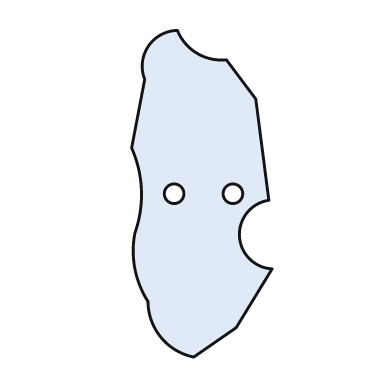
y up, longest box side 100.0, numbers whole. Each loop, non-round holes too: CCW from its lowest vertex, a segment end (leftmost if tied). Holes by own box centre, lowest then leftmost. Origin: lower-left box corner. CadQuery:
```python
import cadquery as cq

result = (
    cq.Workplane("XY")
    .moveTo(19.0, 0.0)
    .lineTo(32.0, 9.0)
    .lineTo(43.0, 27.0)
    .threePointArc((33.0, 37.0), (42.0, 48.0))
    .lineTo(38.0, 79.0)
    .lineTo(29.0, 91.0)
    .threePointArc((20.0, 93.0), (14.0, 100.0))
    .threePointArc((5.0, 95.0), (4.0, 85.0))
    .lineTo(0.0, 64.0)
    .threePointArc((3.0, 51.0), (1.0, 38.0))
    .threePointArc((1.0, 27.0), (5.0, 17.0))
    .threePointArc((9.0, 6.0), (19.0, 0.0))
    .close()
    .moveTo(13.0, 50.0)
    .circle(3.0)
    .moveTo(31.0, 50.0)
    .circle(3.0)
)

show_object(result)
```